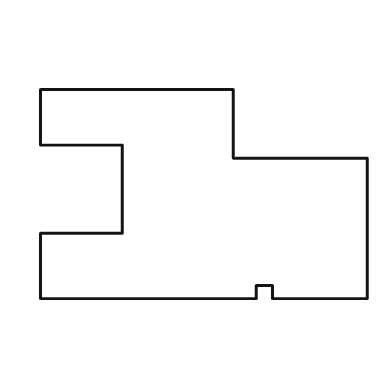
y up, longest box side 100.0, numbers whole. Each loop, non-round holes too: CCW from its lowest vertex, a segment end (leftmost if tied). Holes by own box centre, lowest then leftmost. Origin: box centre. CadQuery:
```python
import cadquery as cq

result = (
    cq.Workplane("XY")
    .moveTo(-50.0, -32.0)
    .lineTo(16.0, -32.0)
    .lineTo(16.0, -28.0)
    .lineTo(21.0, -28.0)
    .lineTo(21.0, -32.0)
    .lineTo(50.0, -32.0)
    .lineTo(50.0, 11.0)
    .lineTo(9.0, 11.0)
    .lineTo(9.0, 32.0)
    .lineTo(-50.0, 32.0)
    .lineTo(-50.0, 15.0)
    .lineTo(-25.0, 15.0)
    .lineTo(-25.0, -12.0)
    .lineTo(-50.0, -12.0)
    .close()
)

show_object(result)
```